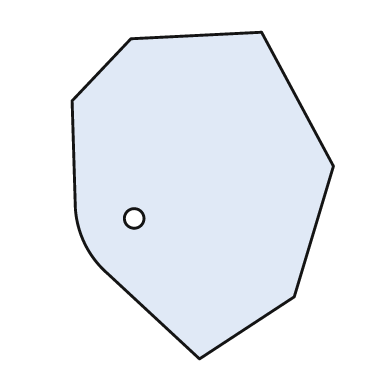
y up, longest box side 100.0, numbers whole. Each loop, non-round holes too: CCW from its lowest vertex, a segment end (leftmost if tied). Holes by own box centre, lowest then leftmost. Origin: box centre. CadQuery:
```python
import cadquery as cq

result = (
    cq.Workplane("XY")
    .moveTo(-1.0, -50.0)
    .lineTo(28.0, -31.0)
    .lineTo(40.0, 9.0)
    .lineTo(18.0, 50.0)
    .lineTo(-22.0, 48.0)
    .lineTo(-40.0, 29.0)
    .lineTo(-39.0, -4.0)
    .threePointArc((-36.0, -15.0), (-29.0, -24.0))
    .close()
    .moveTo(-21.0, -7.0)
    .circle(3.0)
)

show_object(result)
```